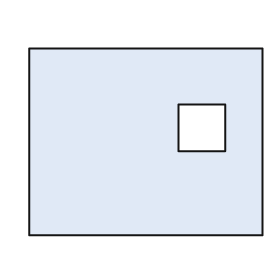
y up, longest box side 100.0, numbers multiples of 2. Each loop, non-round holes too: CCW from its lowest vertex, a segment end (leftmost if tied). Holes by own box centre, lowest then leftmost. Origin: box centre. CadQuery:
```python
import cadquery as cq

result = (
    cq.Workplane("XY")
    .moveTo(-50.0, -40.0)
    .lineTo(50.0, -40.0)
    .lineTo(50.0, 40.0)
    .lineTo(-50.0, 40.0)
    .close()
    .moveTo(14.0, -4.0)
    .lineTo(34.0, -4.0)
    .lineTo(34.0, 16.0)
    .lineTo(14.0, 16.0)
    .close()
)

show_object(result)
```